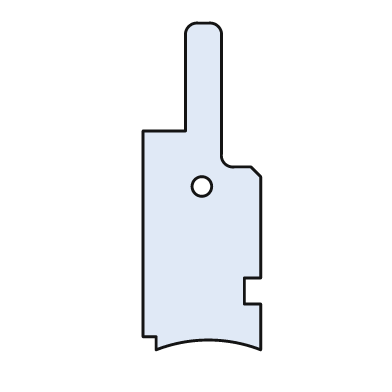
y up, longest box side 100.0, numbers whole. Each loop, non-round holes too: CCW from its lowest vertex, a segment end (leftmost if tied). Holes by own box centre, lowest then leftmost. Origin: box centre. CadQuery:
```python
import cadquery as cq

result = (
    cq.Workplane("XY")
    .moveTo(-14.0, -50.0)
    .threePointArc((2.0, -47.0), (18.0, -50.0))
    .lineTo(18.0, -36.0)
    .lineTo(13.0, -36.0)
    .lineTo(13.0, -28.0)
    .lineTo(18.0, -28.0)
    .lineTo(18.0, 3.0)
    .lineTo(15.0, 6.0)
    .lineTo(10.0, 6.0)
    .threePointArc((7.0, 7.0), (6.0, 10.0))
    .lineTo(6.0, 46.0)
    .threePointArc((5.0, 49.0), (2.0, 50.0))
    .lineTo(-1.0, 50.0)
    .threePointArc((-4.0, 49.0), (-5.0, 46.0))
    .lineTo(-5.0, 17.0)
    .lineTo(-18.0, 17.0)
    .lineTo(-18.0, -46.0)
    .lineTo(-14.0, -46.0)
    .close()
    .moveTo(0.0, 0.0)
    .circle(3.0)
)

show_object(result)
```